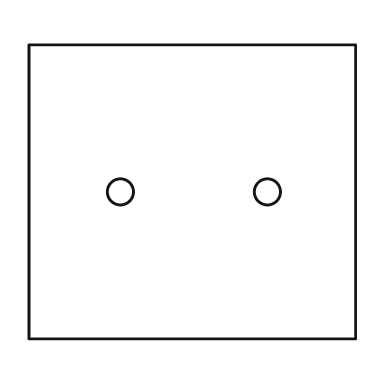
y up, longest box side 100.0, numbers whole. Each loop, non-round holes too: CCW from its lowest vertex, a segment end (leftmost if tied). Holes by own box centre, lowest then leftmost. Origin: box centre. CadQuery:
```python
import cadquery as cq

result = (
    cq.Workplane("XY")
    .moveTo(-50.0, -45.0)
    .lineTo(50.0, -45.0)
    .lineTo(50.0, 45.0)
    .lineTo(-50.0, 45.0)
    .close()
    .moveTo(-22.0, 0.0)
    .circle(4.0)
    .moveTo(23.0, 0.0)
    .circle(4.0)
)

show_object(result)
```